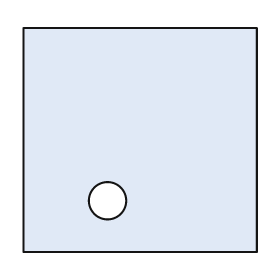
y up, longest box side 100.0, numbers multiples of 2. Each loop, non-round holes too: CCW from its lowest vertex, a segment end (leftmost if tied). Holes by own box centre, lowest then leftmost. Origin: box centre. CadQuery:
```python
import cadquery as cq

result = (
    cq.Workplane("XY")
    .moveTo(-50.0, -48.0)
    .lineTo(50.0, -48.0)
    .lineTo(50.0, 48.0)
    .lineTo(-50.0, 48.0)
    .close()
    .moveTo(-14.0, -26.0)
    .circle(8.0)
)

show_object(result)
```